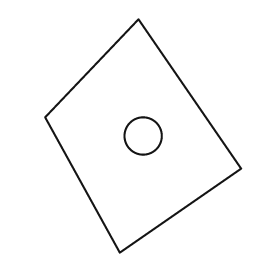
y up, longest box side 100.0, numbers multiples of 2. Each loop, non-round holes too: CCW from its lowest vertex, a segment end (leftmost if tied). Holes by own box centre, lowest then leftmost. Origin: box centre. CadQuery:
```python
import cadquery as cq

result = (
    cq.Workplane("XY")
    .moveTo(-10.0, -50.0)
    .lineTo(42.0, -14.0)
    .lineTo(-2.0, 50.0)
    .lineTo(-42.0, 8.0)
    .close()
    .moveTo(0.0, 0.0)
    .circle(8.0)
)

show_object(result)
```